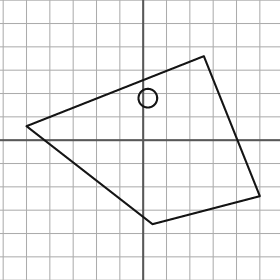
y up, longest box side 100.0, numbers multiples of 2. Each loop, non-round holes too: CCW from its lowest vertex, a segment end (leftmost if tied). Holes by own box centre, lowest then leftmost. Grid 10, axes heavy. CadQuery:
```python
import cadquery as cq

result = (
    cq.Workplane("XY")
    .moveTo(4.0, -36.0)
    .lineTo(50.0, -24.0)
    .lineTo(26.0, 36.0)
    .lineTo(-50.0, 6.0)
    .close()
    .moveTo(2.0, 18.0)
    .circle(4.0)
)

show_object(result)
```